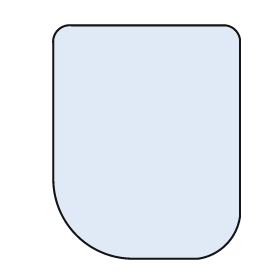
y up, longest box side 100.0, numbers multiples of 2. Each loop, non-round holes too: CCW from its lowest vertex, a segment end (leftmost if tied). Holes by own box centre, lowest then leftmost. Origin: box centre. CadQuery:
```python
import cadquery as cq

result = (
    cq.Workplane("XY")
    .moveTo(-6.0, -50.0)
    .lineTo(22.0, -50.0)
    .threePointArc((34.0, -44.0), (40.0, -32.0))
    .lineTo(40.0, 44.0)
    .threePointArc((38.0, 48.0), (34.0, 50.0))
    .lineTo(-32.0, 50.0)
    .threePointArc((-38.0, 48.0), (-40.0, 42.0))
    .lineTo(-40.0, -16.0)
    .threePointArc((-30.0, -40.0), (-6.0, -50.0))
    .close()
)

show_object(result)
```